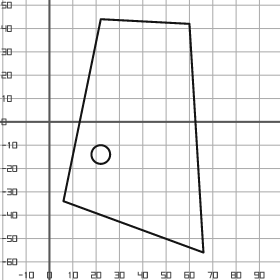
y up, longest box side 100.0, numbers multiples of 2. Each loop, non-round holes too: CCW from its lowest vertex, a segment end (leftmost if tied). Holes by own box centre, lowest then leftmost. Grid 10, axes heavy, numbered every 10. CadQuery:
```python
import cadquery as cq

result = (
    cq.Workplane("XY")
    .moveTo(66.0, -56.0)
    .lineTo(60.0, 42.0)
    .lineTo(22.0, 44.0)
    .lineTo(6.0, -34.0)
    .close()
    .moveTo(22.0, -14.0)
    .circle(4.0)
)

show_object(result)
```